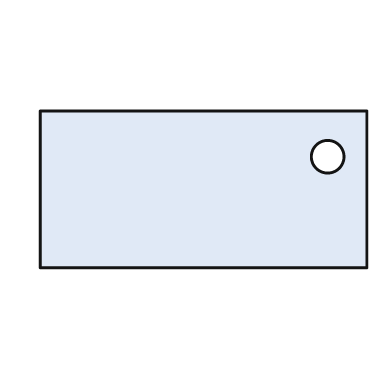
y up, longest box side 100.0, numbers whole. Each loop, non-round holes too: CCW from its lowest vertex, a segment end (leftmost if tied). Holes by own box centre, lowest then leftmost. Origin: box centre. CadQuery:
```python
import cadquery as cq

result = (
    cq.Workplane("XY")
    .moveTo(-50.0, -24.0)
    .lineTo(50.0, -24.0)
    .lineTo(50.0, 24.0)
    .lineTo(-50.0, 24.0)
    .close()
    .moveTo(38.0, 10.0)
    .circle(5.0)
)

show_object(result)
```